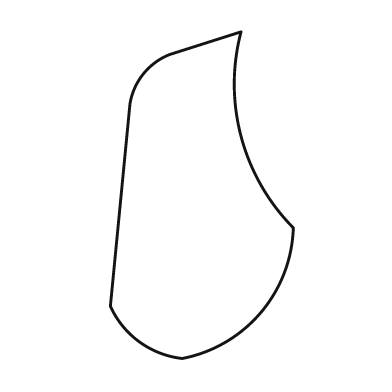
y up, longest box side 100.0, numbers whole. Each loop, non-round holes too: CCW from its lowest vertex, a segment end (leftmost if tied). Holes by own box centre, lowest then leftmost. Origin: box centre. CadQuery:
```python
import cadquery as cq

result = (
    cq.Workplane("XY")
    .moveTo(-6.0, -50.0)
    .threePointArc((18.0, -36.0), (28.0, -10.0))
    .threePointArc((12.0, 18.0), (12.0, 50.0))
    .lineTo(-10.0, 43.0)
    .threePointArc((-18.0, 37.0), (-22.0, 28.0))
    .lineTo(-28.0, -34.0)
    .threePointArc((-19.0, -45.0), (-6.0, -50.0))
    .close()
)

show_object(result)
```